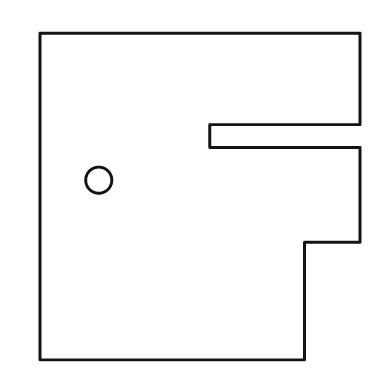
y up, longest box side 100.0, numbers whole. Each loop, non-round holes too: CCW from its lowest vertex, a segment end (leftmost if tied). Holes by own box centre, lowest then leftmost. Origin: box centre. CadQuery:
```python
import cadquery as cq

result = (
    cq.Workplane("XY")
    .moveTo(-49.0, -50.0)
    .lineTo(32.0, -50.0)
    .lineTo(32.0, -14.0)
    .lineTo(49.0, -14.0)
    .lineTo(49.0, 15.0)
    .lineTo(3.0, 15.0)
    .lineTo(3.0, 22.0)
    .lineTo(49.0, 22.0)
    .lineTo(49.0, 50.0)
    .lineTo(-49.0, 50.0)
    .close()
    .moveTo(-31.0, 5.0)
    .circle(4.0)
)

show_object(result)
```